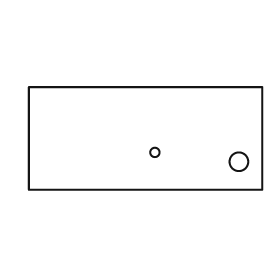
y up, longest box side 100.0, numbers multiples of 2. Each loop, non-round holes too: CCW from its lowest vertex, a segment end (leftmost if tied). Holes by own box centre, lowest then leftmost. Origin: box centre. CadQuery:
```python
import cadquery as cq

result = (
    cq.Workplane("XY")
    .moveTo(-50.0, -22.0)
    .lineTo(50.0, -22.0)
    .lineTo(50.0, 22.0)
    .lineTo(-50.0, 22.0)
    .close()
    .moveTo(40.0, -10.0)
    .circle(4.0)
    .moveTo(4.0, -6.0)
    .circle(2.0)
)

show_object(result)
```